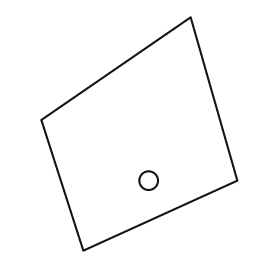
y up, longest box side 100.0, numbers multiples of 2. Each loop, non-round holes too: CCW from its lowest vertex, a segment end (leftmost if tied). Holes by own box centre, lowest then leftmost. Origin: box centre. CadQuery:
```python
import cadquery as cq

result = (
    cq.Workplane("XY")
    .moveTo(-24.0, -50.0)
    .lineTo(42.0, -20.0)
    .lineTo(22.0, 50.0)
    .lineTo(-42.0, 6.0)
    .close()
    .moveTo(4.0, -20.0)
    .circle(4.0)
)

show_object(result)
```